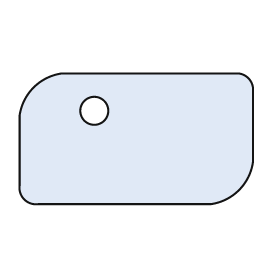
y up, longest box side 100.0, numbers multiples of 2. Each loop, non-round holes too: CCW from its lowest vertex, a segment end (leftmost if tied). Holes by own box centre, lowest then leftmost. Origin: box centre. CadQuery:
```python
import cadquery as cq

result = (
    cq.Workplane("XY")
    .moveTo(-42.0, -28.0)
    .lineTo(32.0, -28.0)
    .threePointArc((44.0, -22.0), (50.0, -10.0))
    .lineTo(50.0, 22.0)
    .threePointArc((48.0, 26.0), (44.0, 28.0))
    .lineTo(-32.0, 28.0)
    .threePointArc((-44.0, 22.0), (-50.0, 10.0))
    .lineTo(-50.0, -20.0)
    .threePointArc((-48.0, -26.0), (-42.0, -28.0))
    .close()
    .moveTo(-18.0, 12.0)
    .circle(6.0)
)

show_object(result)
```